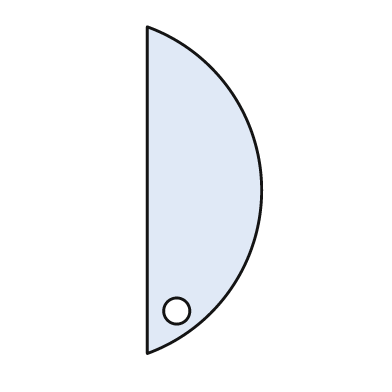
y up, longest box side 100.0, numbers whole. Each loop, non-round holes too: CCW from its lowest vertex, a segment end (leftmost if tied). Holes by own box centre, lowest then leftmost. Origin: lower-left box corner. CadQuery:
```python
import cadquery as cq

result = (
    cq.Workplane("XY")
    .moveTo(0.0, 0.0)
    .threePointArc((35.0, 50.0), (0.0, 100.0))
    .close()
    .moveTo(9.0, 13.0)
    .circle(4.0)
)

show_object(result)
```